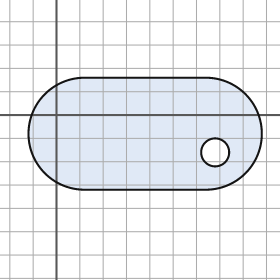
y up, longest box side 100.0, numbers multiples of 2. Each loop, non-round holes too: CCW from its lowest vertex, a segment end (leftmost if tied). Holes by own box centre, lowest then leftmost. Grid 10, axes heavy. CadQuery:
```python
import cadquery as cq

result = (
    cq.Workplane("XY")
    .moveTo(12.0, -32.0)
    .lineTo(64.0, -32.0)
    .threePointArc((88.0, -8.0), (64.0, 16.0))
    .lineTo(12.0, 16.0)
    .threePointArc((-12.0, -8.0), (12.0, -32.0))
    .close()
    .moveTo(68.0, -16.0)
    .circle(6.0)
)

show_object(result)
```